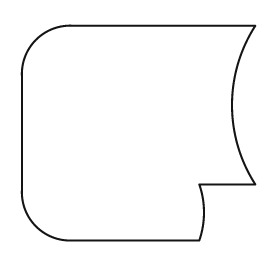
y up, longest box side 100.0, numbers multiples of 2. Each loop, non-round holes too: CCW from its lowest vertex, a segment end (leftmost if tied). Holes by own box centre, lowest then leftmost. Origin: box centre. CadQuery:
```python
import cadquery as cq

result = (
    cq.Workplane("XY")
    .moveTo(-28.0, -46.0)
    .lineTo(26.0, -46.0)
    .threePointArc((28.0, -34.0), (26.0, -22.0))
    .lineTo(50.0, -22.0)
    .threePointArc((40.0, 12.0), (50.0, 46.0))
    .lineTo(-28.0, 46.0)
    .threePointArc((-44.0, 40.0), (-50.0, 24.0))
    .lineTo(-50.0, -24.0)
    .threePointArc((-44.0, -40.0), (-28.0, -46.0))
    .close()
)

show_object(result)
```